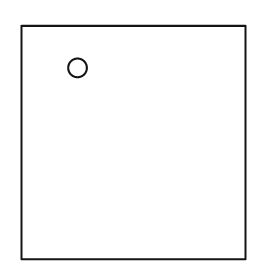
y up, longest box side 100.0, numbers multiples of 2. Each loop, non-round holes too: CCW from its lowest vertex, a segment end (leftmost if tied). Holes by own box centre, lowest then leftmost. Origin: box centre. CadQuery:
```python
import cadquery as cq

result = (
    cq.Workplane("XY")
    .moveTo(-48.0, -50.0)
    .lineTo(48.0, -50.0)
    .lineTo(48.0, 50.0)
    .lineTo(-48.0, 50.0)
    .close()
    .moveTo(-24.0, 32.0)
    .circle(4.0)
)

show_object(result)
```